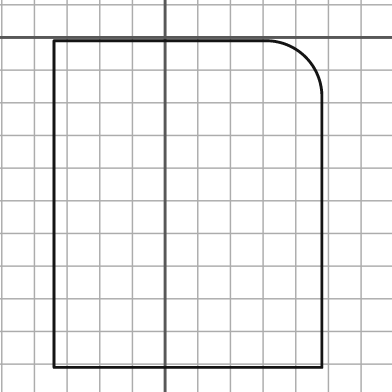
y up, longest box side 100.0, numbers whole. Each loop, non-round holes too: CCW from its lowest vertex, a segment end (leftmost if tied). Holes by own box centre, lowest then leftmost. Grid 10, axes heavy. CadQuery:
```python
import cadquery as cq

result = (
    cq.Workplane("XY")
    .moveTo(-34.0, -101.0)
    .lineTo(48.0, -101.0)
    .lineTo(48.0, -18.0)
    .threePointArc((43.0, -6.0), (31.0, -1.0))
    .lineTo(-34.0, -1.0)
    .close()
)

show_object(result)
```